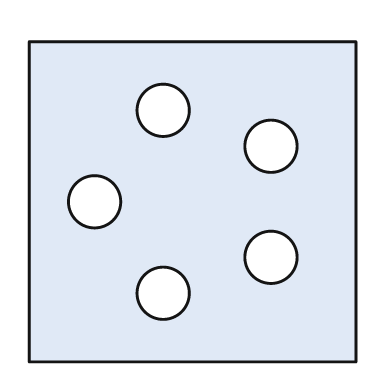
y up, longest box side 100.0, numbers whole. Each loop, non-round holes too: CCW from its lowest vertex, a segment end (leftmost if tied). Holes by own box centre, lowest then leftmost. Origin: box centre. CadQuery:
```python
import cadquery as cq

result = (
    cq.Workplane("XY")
    .moveTo(-50.0, -49.0)
    .lineTo(50.0, -49.0)
    .lineTo(50.0, 49.0)
    .lineTo(-50.0, 49.0)
    .close()
    .moveTo(-9.0, -28.0)
    .circle(8.0)
    .moveTo(24.0, -17.0)
    .circle(8.0)
    .moveTo(-30.0, 0.0)
    .circle(8.0)
    .moveTo(24.0, 17.0)
    .circle(8.0)
    .moveTo(-9.0, 28.0)
    .circle(8.0)
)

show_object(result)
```